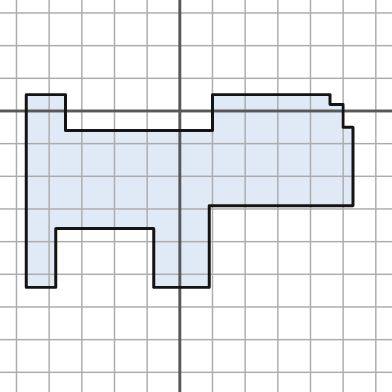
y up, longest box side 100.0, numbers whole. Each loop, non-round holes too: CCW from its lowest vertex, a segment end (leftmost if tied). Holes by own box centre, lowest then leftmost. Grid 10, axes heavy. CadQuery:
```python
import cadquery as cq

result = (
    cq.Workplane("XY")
    .moveTo(-47.0, -54.0)
    .lineTo(-38.0, -54.0)
    .lineTo(-38.0, -36.0)
    .lineTo(-8.0, -36.0)
    .lineTo(-8.0, -54.0)
    .lineTo(9.0, -54.0)
    .lineTo(9.0, -29.0)
    .lineTo(53.0, -29.0)
    .lineTo(53.0, -5.0)
    .lineTo(50.0, -5.0)
    .lineTo(50.0, 2.0)
    .lineTo(46.0, 2.0)
    .lineTo(46.0, 5.0)
    .lineTo(10.0, 5.0)
    .lineTo(10.0, -6.0)
    .lineTo(-35.0, -6.0)
    .lineTo(-35.0, 5.0)
    .lineTo(-47.0, 5.0)
    .close()
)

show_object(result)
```